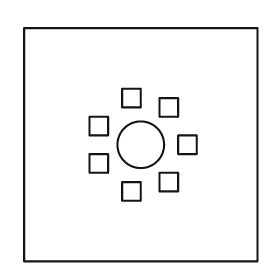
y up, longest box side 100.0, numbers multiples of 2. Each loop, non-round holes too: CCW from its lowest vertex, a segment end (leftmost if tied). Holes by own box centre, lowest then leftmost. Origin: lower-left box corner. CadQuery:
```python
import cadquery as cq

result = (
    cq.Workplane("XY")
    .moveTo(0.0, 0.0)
    .lineTo(100.0, 0.0)
    .lineTo(100.0, 100.0)
    .lineTo(0.0, 100.0)
    .close()
    .moveTo(42.0, 26.0)
    .lineTo(50.0, 26.0)
    .lineTo(50.0, 34.0)
    .lineTo(42.0, 34.0)
    .close()
    .moveTo(58.0, 30.0)
    .lineTo(66.0, 30.0)
    .lineTo(66.0, 38.0)
    .lineTo(58.0, 38.0)
    .close()
    .moveTo(28.0, 38.0)
    .lineTo(36.0, 38.0)
    .lineTo(36.0, 46.0)
    .lineTo(28.0, 46.0)
    .close()
    .moveTo(50.0, 50.0)
    .circle(10.0)
    .moveTo(66.0, 46.0)
    .lineTo(74.0, 46.0)
    .lineTo(74.0, 54.0)
    .lineTo(66.0, 54.0)
    .close()
    .moveTo(28.0, 54.0)
    .lineTo(36.0, 54.0)
    .lineTo(36.0, 62.0)
    .lineTo(28.0, 62.0)
    .close()
    .moveTo(58.0, 62.0)
    .lineTo(66.0, 62.0)
    .lineTo(66.0, 70.0)
    .lineTo(58.0, 70.0)
    .close()
    .moveTo(42.0, 66.0)
    .lineTo(50.0, 66.0)
    .lineTo(50.0, 74.0)
    .lineTo(42.0, 74.0)
    .close()
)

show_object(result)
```